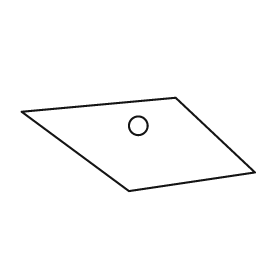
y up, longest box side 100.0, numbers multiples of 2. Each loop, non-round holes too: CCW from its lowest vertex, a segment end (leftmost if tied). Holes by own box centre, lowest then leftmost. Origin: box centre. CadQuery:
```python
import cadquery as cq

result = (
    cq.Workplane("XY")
    .moveTo(-4.0, -20.0)
    .lineTo(50.0, -12.0)
    .lineTo(16.0, 20.0)
    .lineTo(-50.0, 14.0)
    .close()
    .moveTo(0.0, 8.0)
    .circle(4.0)
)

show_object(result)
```